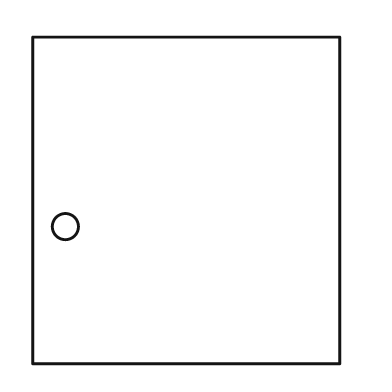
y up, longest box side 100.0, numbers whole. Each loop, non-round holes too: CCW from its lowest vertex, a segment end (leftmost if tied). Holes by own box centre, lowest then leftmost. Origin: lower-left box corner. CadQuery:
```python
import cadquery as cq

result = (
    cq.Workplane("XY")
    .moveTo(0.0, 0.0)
    .lineTo(94.0, 0.0)
    .lineTo(94.0, 100.0)
    .lineTo(0.0, 100.0)
    .close()
    .moveTo(10.0, 42.0)
    .circle(4.0)
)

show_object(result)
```